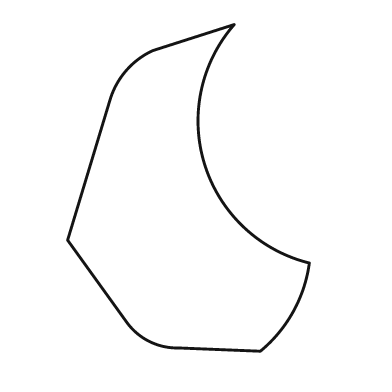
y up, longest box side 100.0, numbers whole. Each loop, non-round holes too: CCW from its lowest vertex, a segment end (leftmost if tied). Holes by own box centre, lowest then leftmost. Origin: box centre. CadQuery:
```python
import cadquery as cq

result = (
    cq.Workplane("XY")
    .moveTo(22.0, -50.0)
    .threePointArc((32.0, -38.0), (37.0, -23.0))
    .threePointArc((5.0, 7.0), (14.0, 50.0))
    .lineTo(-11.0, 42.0)
    .threePointArc((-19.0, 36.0), (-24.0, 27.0))
    .lineTo(-37.0, -16.0)
    .lineTo(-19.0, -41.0)
    .threePointArc((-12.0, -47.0), (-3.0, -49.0))
    .close()
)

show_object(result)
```